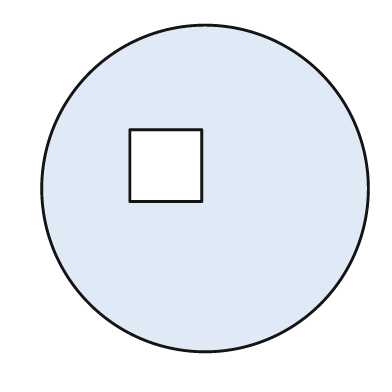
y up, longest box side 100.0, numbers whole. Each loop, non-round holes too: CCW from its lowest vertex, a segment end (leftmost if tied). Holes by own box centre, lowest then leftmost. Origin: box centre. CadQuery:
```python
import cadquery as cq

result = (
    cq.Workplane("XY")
    .moveTo(0.0, 0.0)
    .circle(50.0)
    .moveTo(-23.0, -4.0)
    .lineTo(-1.0, -4.0)
    .lineTo(-1.0, 18.0)
    .lineTo(-23.0, 18.0)
    .close()
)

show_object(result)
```